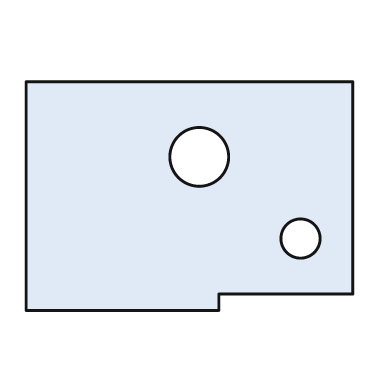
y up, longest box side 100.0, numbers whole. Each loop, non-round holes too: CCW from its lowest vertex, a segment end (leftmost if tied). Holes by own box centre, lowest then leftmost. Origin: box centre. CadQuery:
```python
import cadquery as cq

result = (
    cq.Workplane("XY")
    .moveTo(-50.0, -35.0)
    .lineTo(9.0, -35.0)
    .lineTo(9.0, -30.0)
    .lineTo(50.0, -30.0)
    .lineTo(50.0, 35.0)
    .lineTo(-50.0, 35.0)
    .close()
    .moveTo(34.0, -13.0)
    .circle(6.0)
    .moveTo(3.0, 12.0)
    .circle(9.0)
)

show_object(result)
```